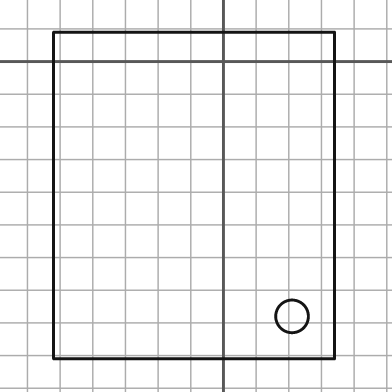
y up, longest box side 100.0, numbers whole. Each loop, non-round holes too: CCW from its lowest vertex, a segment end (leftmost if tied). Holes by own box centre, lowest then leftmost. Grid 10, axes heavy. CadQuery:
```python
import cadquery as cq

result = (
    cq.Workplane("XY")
    .moveTo(-52.0, -91.0)
    .lineTo(34.0, -91.0)
    .lineTo(34.0, 9.0)
    .lineTo(-52.0, 9.0)
    .close()
    .moveTo(21.0, -78.0)
    .circle(5.0)
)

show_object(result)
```